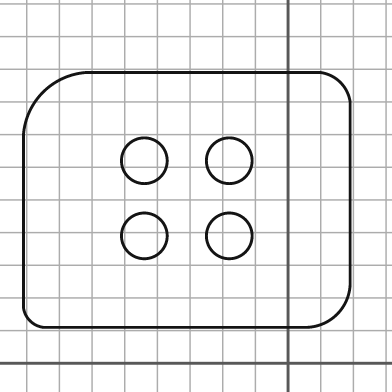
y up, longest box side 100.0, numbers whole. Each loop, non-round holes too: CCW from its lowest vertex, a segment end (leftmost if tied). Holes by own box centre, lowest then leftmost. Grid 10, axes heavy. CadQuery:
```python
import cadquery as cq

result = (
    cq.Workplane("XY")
    .moveTo(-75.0, 11.0)
    .lineTo(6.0, 11.0)
    .threePointArc((15.0, 15.0), (19.0, 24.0))
    .lineTo(19.0, 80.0)
    .threePointArc((16.0, 86.0), (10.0, 89.0))
    .lineTo(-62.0, 89.0)
    .threePointArc((-75.0, 83.0), (-81.0, 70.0))
    .lineTo(-81.0, 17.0)
    .threePointArc((-79.0, 13.0), (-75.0, 11.0))
    .close()
    .moveTo(-44.0, 39.0)
    .circle(7.0)
    .moveTo(-18.0, 39.0)
    .circle(7.0)
    .moveTo(-44.0, 62.0)
    .circle(7.0)
    .moveTo(-18.0, 62.0)
    .circle(7.0)
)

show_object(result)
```